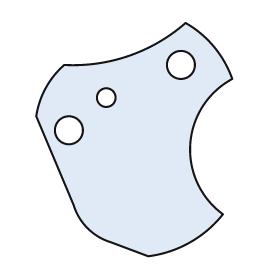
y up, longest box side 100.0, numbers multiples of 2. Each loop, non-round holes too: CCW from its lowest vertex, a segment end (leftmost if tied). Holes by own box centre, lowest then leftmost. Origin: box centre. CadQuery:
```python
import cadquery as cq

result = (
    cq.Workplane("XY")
    .moveTo(6.0, -50.0)
    .threePointArc((24.0, -44.0), (38.0, -32.0))
    .threePointArc((24.0, -2.0), (42.0, 26.0))
    .threePointArc((34.0, 40.0), (22.0, 50.0))
    .threePointArc((-2.0, 36.0), (-30.0, 32.0))
    .threePointArc((-38.0, 22.0), (-42.0, 10.0))
    .lineTo(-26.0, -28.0)
    .threePointArc((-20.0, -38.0), (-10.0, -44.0))
    .close()
    .moveTo(-28.0, 4.0)
    .circle(6.0)
    .moveTo(-12.0, 18.0)
    .circle(4.0)
    .moveTo(20.0, 32.0)
    .circle(6.0)
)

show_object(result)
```